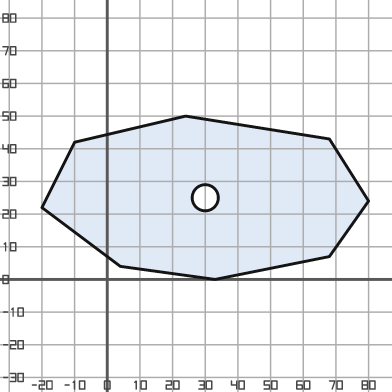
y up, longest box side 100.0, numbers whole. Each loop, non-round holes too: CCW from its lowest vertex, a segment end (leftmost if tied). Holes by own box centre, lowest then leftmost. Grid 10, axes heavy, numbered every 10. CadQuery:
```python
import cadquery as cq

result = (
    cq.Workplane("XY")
    .moveTo(33.0, 0.0)
    .lineTo(68.0, 7.0)
    .lineTo(80.0, 24.0)
    .lineTo(68.0, 43.0)
    .lineTo(24.0, 50.0)
    .lineTo(-10.0, 42.0)
    .lineTo(-20.0, 22.0)
    .lineTo(4.0, 4.0)
    .close()
    .moveTo(30.0, 25.0)
    .circle(4.0)
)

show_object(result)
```